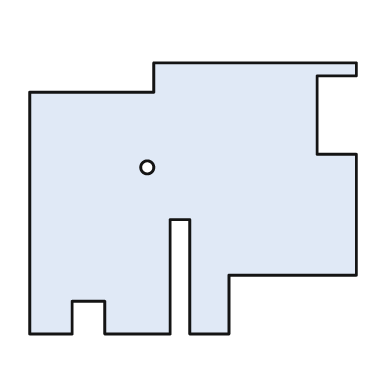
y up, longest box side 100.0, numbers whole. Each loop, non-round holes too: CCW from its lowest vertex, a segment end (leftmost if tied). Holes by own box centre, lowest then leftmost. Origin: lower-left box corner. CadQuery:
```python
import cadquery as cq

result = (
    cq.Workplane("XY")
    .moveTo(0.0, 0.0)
    .lineTo(13.0, 0.0)
    .lineTo(13.0, 10.0)
    .lineTo(23.0, 10.0)
    .lineTo(23.0, 0.0)
    .lineTo(43.0, 0.0)
    .lineTo(43.0, 35.0)
    .lineTo(49.0, 35.0)
    .lineTo(49.0, 0.0)
    .lineTo(61.0, 0.0)
    .lineTo(61.0, 18.0)
    .lineTo(100.0, 18.0)
    .lineTo(100.0, 55.0)
    .lineTo(88.0, 55.0)
    .lineTo(88.0, 79.0)
    .lineTo(100.0, 79.0)
    .lineTo(100.0, 83.0)
    .lineTo(38.0, 83.0)
    .lineTo(38.0, 74.0)
    .lineTo(0.0, 74.0)
    .close()
    .moveTo(36.0, 51.0)
    .circle(2.0)
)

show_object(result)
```